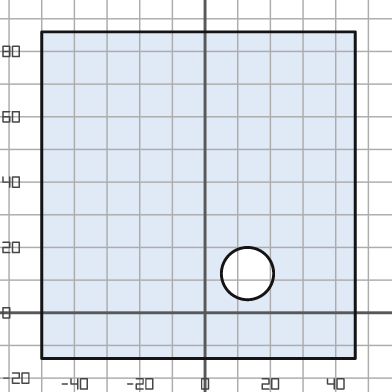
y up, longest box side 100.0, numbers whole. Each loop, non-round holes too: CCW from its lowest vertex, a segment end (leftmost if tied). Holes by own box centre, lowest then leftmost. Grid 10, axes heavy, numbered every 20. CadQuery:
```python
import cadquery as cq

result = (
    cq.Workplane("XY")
    .moveTo(-50.0, -14.0)
    .lineTo(46.0, -14.0)
    .lineTo(46.0, 86.0)
    .lineTo(-50.0, 86.0)
    .close()
    .moveTo(13.0, 12.0)
    .circle(8.0)
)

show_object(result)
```